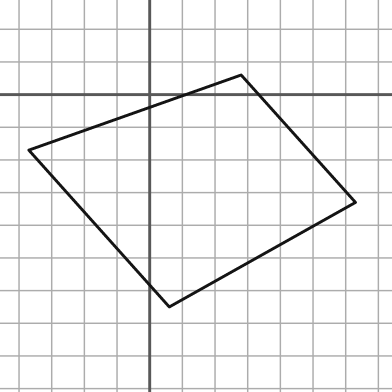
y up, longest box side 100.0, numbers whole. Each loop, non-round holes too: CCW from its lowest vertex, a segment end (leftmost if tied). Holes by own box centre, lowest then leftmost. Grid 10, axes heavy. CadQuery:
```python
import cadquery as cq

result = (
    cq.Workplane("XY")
    .moveTo(6.0, -65.0)
    .lineTo(63.0, -33.0)
    .lineTo(28.0, 6.0)
    .lineTo(-37.0, -17.0)
    .close()
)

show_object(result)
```